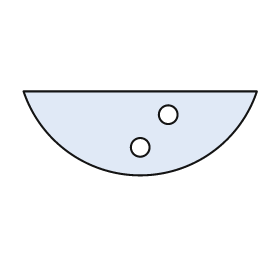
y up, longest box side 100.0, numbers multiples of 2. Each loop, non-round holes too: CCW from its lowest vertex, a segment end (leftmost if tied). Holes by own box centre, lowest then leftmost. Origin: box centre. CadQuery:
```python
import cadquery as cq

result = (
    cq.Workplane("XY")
    .moveTo(-50.0, 18.0)
    .threePointArc((0.0, -18.0), (50.0, 18.0))
    .close()
    .moveTo(0.0, -6.0)
    .circle(4.0)
    .moveTo(12.0, 8.0)
    .circle(4.0)
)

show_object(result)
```